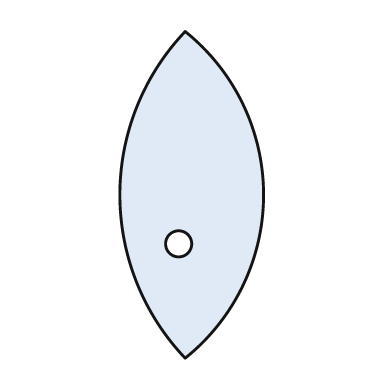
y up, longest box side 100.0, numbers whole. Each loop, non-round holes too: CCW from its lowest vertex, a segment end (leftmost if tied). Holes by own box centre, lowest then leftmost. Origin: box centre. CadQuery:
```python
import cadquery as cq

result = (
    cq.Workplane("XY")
    .moveTo(-2.0, -50.0)
    .threePointArc((22.0, 0.0), (-2.0, 50.0))
    .threePointArc((-22.0, 0.0), (-2.0, -50.0))
    .close()
    .moveTo(-4.0, -15.0)
    .circle(4.0)
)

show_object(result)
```